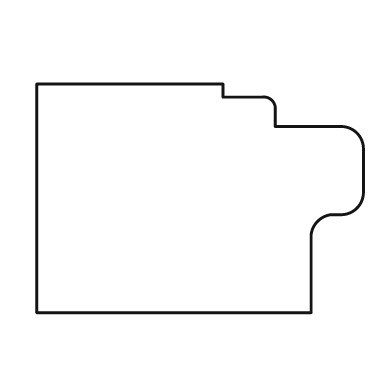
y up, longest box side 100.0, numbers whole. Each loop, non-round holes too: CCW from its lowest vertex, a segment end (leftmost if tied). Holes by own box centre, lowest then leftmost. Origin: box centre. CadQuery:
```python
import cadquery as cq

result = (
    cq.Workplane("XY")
    .moveTo(-50.0, -35.0)
    .lineTo(34.0, -35.0)
    .lineTo(34.0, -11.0)
    .threePointArc((36.0, -7.0), (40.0, -5.0))
    .lineTo(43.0, -5.0)
    .threePointArc((48.0, -3.0), (50.0, 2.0))
    .lineTo(50.0, 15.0)
    .threePointArc((48.0, 20.0), (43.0, 22.0))
    .lineTo(23.0, 22.0)
    .lineTo(23.0, 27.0)
    .threePointArc((22.0, 30.0), (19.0, 31.0))
    .lineTo(7.0, 31.0)
    .lineTo(7.0, 35.0)
    .lineTo(-50.0, 35.0)
    .close()
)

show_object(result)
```